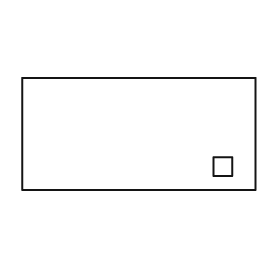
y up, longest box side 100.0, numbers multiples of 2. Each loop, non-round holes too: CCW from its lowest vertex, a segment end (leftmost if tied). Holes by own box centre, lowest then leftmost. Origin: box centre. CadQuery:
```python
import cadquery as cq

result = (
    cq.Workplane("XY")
    .moveTo(-50.0, -24.0)
    .lineTo(50.0, -24.0)
    .lineTo(50.0, 24.0)
    .lineTo(-50.0, 24.0)
    .close()
    .moveTo(32.0, -18.0)
    .lineTo(40.0, -18.0)
    .lineTo(40.0, -10.0)
    .lineTo(32.0, -10.0)
    .close()
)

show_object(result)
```